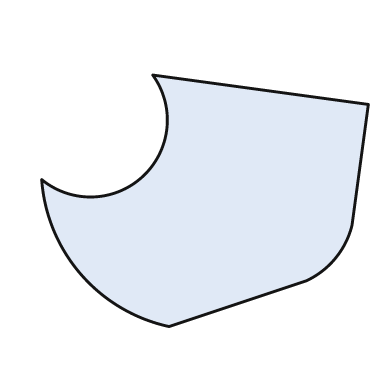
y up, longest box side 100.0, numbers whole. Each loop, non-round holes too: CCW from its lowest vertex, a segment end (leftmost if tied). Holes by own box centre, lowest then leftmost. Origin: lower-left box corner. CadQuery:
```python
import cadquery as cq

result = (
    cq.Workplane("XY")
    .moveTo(39.0, 0.0)
    .lineTo(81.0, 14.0)
    .threePointArc((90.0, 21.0), (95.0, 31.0))
    .lineTo(100.0, 68.0)
    .lineTo(34.0, 77.0)
    .threePointArc((31.0, 46.0), (0.0, 45.0))
    .threePointArc((12.0, 16.0), (39.0, 0.0))
    .close()
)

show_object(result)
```